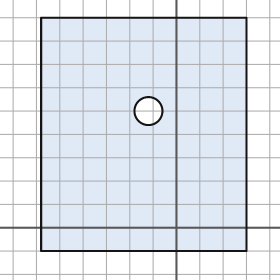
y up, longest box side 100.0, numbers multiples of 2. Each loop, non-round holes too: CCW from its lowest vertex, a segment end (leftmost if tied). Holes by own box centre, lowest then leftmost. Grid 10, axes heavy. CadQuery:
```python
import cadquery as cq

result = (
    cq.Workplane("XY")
    .moveTo(-58.0, -10.0)
    .lineTo(30.0, -10.0)
    .lineTo(30.0, 90.0)
    .lineTo(-58.0, 90.0)
    .close()
    .moveTo(-12.0, 50.0)
    .circle(6.0)
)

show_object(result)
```